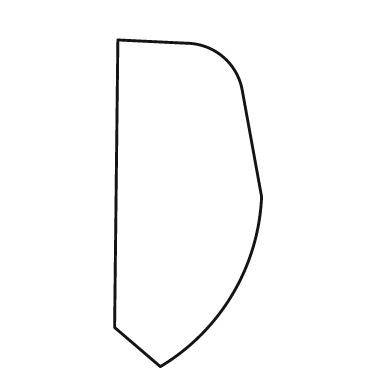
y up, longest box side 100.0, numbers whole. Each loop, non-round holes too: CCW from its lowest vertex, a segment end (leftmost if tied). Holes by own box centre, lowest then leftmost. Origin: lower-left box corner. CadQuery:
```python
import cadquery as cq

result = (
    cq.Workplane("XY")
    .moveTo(14.0, 0.0)
    .threePointArc((36.0, 22.0), (45.0, 52.0))
    .lineTo(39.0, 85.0)
    .threePointArc((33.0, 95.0), (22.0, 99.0))
    .lineTo(1.0, 100.0)
    .lineTo(0.0, 12.0)
    .close()
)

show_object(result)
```